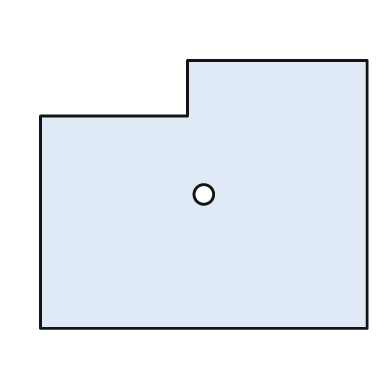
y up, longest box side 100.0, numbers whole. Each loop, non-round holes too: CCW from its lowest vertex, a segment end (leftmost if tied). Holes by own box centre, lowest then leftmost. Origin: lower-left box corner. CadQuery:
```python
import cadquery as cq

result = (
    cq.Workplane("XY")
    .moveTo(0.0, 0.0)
    .lineTo(100.0, 0.0)
    .lineTo(100.0, 82.0)
    .lineTo(45.0, 82.0)
    .lineTo(45.0, 65.0)
    .lineTo(0.0, 65.0)
    .close()
    .moveTo(50.0, 41.0)
    .circle(3.0)
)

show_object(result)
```